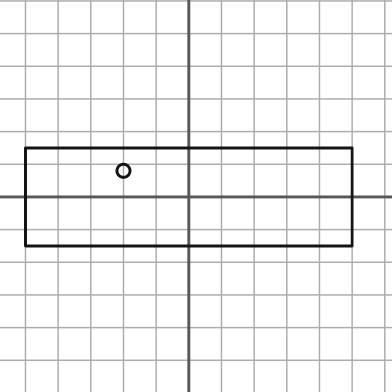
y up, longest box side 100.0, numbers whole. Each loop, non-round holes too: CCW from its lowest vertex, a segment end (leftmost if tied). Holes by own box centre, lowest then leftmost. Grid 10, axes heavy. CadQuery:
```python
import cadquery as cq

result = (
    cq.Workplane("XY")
    .moveTo(-50.0, -15.0)
    .lineTo(50.0, -15.0)
    .lineTo(50.0, 15.0)
    .lineTo(-50.0, 15.0)
    .close()
    .moveTo(-20.0, 8.0)
    .circle(2.0)
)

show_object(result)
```